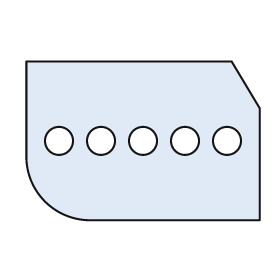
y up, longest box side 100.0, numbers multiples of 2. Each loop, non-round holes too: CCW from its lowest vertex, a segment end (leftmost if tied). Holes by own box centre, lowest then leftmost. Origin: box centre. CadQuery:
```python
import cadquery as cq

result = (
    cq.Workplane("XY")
    .moveTo(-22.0, -34.0)
    .lineTo(50.0, -34.0)
    .lineTo(50.0, 14.0)
    .lineTo(38.0, 34.0)
    .lineTo(-50.0, 34.0)
    .lineTo(-50.0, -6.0)
    .threePointArc((-42.0, -26.0), (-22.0, -34.0))
    .close()
    .moveTo(-36.0, 0.0)
    .circle(6.0)
    .moveTo(-18.0, 0.0)
    .circle(6.0)
    .moveTo(0.0, 0.0)
    .circle(6.0)
    .moveTo(18.0, 0.0)
    .circle(6.0)
    .moveTo(36.0, 0.0)
    .circle(6.0)
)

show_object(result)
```